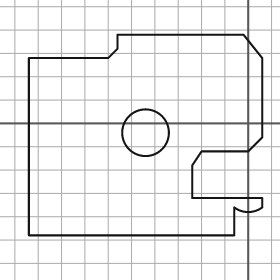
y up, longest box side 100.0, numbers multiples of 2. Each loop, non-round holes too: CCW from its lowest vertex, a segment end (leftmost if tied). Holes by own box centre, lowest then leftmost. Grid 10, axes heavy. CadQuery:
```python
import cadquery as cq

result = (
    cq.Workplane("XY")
    .moveTo(-94.0, -48.0)
    .lineTo(-6.0, -48.0)
    .lineTo(-6.0, -36.0)
    .threePointArc((0.0, -38.0), (6.0, -36.0))
    .lineTo(6.0, -32.0)
    .lineTo(-24.0, -32.0)
    .lineTo(-24.0, -18.0)
    .lineTo(-20.0, -12.0)
    .lineTo(0.0, -12.0)
    .lineTo(6.0, -6.0)
    .lineTo(6.0, 28.0)
    .lineTo(-2.0, 38.0)
    .lineTo(-56.0, 38.0)
    .lineTo(-56.0, 32.0)
    .lineTo(-60.0, 28.0)
    .lineTo(-94.0, 28.0)
    .close()
    .moveTo(-44.0, -4.0)
    .circle(10.0)
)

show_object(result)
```